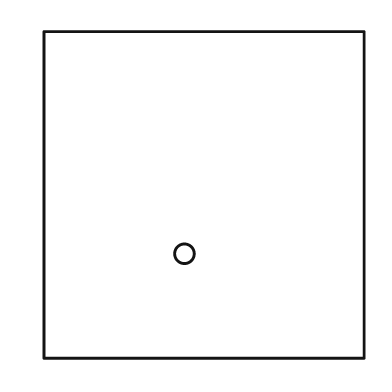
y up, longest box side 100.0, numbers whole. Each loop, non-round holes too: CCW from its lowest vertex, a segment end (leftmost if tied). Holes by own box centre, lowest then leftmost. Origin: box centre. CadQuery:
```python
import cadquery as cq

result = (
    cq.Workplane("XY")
    .moveTo(-49.0, -50.0)
    .lineTo(49.0, -50.0)
    .lineTo(49.0, 50.0)
    .lineTo(-49.0, 50.0)
    .close()
    .moveTo(-6.0, -18.0)
    .circle(3.0)
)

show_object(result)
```